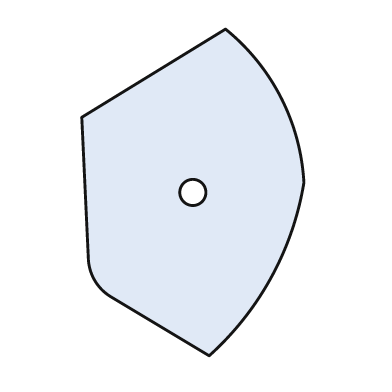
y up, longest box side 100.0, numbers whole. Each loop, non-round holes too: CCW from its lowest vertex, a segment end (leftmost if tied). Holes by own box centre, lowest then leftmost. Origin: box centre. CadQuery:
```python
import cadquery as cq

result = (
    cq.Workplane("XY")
    .moveTo(5.0, -50.0)
    .threePointArc((24.0, -26.0), (34.0, 3.0))
    .threePointArc((27.0, 29.0), (10.0, 50.0))
    .lineTo(-34.0, 23.0)
    .lineTo(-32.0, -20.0)
    .threePointArc((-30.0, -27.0), (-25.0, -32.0))
    .close()
    .moveTo(0.0, 0.0)
    .circle(4.0)
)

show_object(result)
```